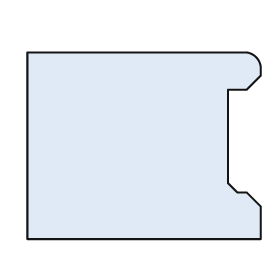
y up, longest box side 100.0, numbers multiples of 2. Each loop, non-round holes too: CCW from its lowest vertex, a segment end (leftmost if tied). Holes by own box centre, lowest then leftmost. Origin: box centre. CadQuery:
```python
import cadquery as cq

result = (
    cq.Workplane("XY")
    .moveTo(-50.0, -40.0)
    .lineTo(50.0, -40.0)
    .lineTo(50.0, -26.0)
    .lineTo(44.0, -20.0)
    .lineTo(40.0, -20.0)
    .lineTo(36.0, -16.0)
    .lineTo(36.0, 24.0)
    .lineTo(44.0, 24.0)
    .lineTo(50.0, 30.0)
    .lineTo(50.0, 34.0)
    .threePointArc((48.0, 38.0), (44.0, 40.0))
    .lineTo(-50.0, 40.0)
    .close()
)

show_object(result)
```